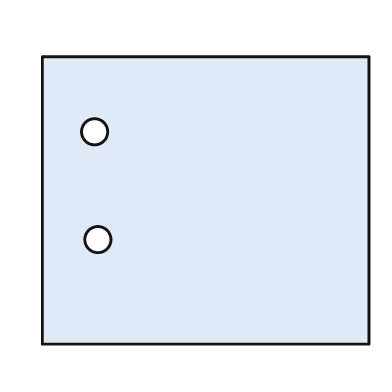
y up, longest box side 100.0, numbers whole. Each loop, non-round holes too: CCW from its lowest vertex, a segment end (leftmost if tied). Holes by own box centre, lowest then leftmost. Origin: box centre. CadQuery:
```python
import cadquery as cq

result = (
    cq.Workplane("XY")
    .moveTo(-50.0, -44.0)
    .lineTo(50.0, -44.0)
    .lineTo(50.0, 44.0)
    .lineTo(-50.0, 44.0)
    .close()
    .moveTo(-33.0, -12.0)
    .circle(4.0)
    .moveTo(-34.0, 21.0)
    .circle(4.0)
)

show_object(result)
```